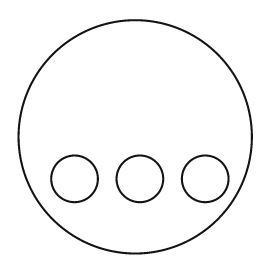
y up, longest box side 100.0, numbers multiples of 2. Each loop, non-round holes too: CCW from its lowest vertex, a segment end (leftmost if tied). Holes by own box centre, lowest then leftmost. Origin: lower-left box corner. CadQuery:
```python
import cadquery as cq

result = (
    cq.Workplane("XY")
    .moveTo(50.0, 50.0)
    .circle(50.0)
    .moveTo(24.0, 32.0)
    .circle(10.0)
    .moveTo(52.0, 32.0)
    .circle(10.0)
    .moveTo(80.0, 32.0)
    .circle(10.0)
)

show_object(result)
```